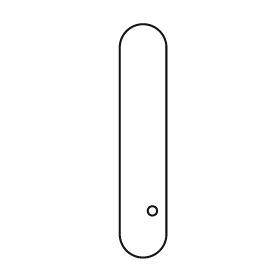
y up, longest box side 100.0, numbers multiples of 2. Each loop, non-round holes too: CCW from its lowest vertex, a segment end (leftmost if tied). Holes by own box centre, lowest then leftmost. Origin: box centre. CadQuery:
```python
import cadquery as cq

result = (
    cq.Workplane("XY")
    .moveTo(-10.0, -40.0)
    .threePointArc((0.0, -50.0), (10.0, -40.0))
    .lineTo(10.0, 40.0)
    .threePointArc((0.0, 50.0), (-10.0, 40.0))
    .close()
    .moveTo(4.0, -30.0)
    .circle(2.0)
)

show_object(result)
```